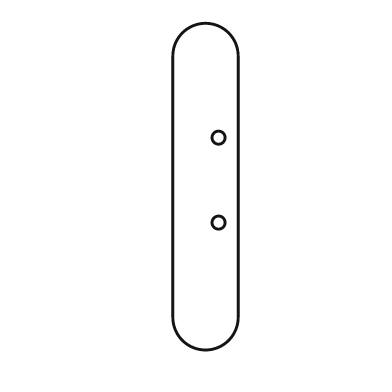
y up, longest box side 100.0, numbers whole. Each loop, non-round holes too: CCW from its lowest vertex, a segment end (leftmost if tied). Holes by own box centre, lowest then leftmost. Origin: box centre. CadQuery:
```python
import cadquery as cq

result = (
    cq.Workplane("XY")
    .moveTo(-10.0, -40.0)
    .threePointArc((0.0, -50.0), (10.0, -40.0))
    .lineTo(10.0, 40.0)
    .threePointArc((0.0, 50.0), (-10.0, 40.0))
    .close()
    .moveTo(4.0, -11.0)
    .circle(2.0)
    .moveTo(4.0, 15.0)
    .circle(2.0)
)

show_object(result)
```